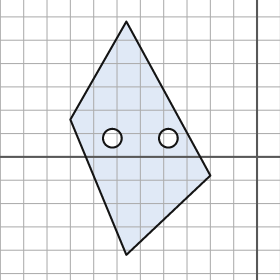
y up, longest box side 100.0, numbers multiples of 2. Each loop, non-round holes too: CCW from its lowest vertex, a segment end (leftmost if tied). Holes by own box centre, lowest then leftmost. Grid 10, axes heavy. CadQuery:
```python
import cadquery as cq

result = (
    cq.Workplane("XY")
    .moveTo(-56.0, -42.0)
    .lineTo(-20.0, -8.0)
    .lineTo(-56.0, 58.0)
    .lineTo(-80.0, 16.0)
    .close()
    .moveTo(-62.0, 8.0)
    .circle(4.0)
    .moveTo(-38.0, 8.0)
    .circle(4.0)
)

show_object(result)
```